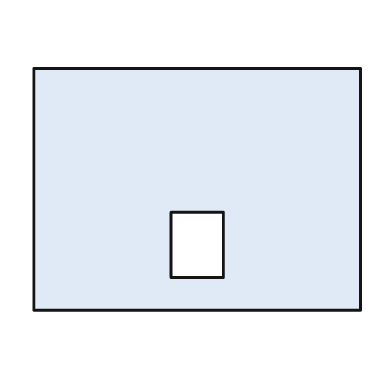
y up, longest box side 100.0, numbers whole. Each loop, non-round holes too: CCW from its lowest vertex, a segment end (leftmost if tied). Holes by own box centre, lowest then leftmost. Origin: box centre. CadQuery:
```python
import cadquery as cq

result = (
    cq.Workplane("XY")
    .moveTo(-50.0, -37.0)
    .lineTo(50.0, -37.0)
    .lineTo(50.0, 37.0)
    .lineTo(-50.0, 37.0)
    .close()
    .moveTo(-8.0, -27.0)
    .lineTo(8.0, -27.0)
    .lineTo(8.0, -7.0)
    .lineTo(-8.0, -7.0)
    .close()
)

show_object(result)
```